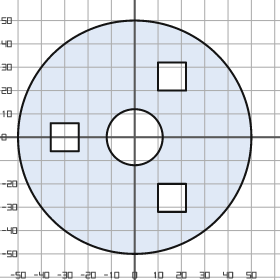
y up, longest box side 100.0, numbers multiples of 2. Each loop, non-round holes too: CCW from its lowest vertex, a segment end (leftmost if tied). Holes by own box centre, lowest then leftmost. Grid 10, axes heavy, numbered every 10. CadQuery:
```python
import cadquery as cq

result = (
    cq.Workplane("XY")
    .moveTo(0.0, 0.0)
    .circle(50.0)
    .moveTo(10.0, -32.0)
    .lineTo(22.0, -32.0)
    .lineTo(22.0, -20.0)
    .lineTo(10.0, -20.0)
    .close()
    .moveTo(-36.0, -6.0)
    .lineTo(-24.0, -6.0)
    .lineTo(-24.0, 6.0)
    .lineTo(-36.0, 6.0)
    .close()
    .moveTo(0.0, 0.0)
    .circle(12.0)
    .moveTo(10.0, 20.0)
    .lineTo(22.0, 20.0)
    .lineTo(22.0, 32.0)
    .lineTo(10.0, 32.0)
    .close()
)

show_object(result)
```